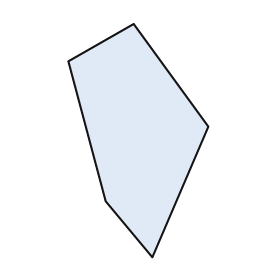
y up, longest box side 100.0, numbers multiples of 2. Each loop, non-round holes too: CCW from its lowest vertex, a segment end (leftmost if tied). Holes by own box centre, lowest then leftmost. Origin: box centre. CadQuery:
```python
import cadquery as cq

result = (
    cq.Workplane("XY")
    .moveTo(6.0, -50.0)
    .lineTo(30.0, 6.0)
    .lineTo(-2.0, 50.0)
    .lineTo(-30.0, 34.0)
    .lineTo(-14.0, -26.0)
    .close()
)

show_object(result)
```